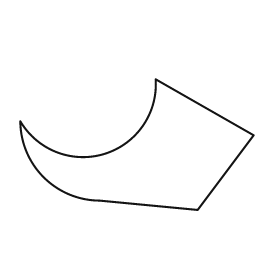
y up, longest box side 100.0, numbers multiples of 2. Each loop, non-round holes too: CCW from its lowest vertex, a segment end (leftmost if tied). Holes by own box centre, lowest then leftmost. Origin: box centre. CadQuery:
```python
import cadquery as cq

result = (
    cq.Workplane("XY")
    .moveTo(26.0, -28.0)
    .lineTo(50.0, 4.0)
    .lineTo(8.0, 28.0)
    .threePointArc((-14.0, -4.0), (-50.0, 10.0))
    .threePointArc((-40.0, -14.0), (-16.0, -24.0))
    .close()
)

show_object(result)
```